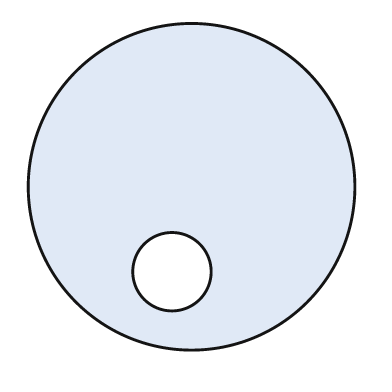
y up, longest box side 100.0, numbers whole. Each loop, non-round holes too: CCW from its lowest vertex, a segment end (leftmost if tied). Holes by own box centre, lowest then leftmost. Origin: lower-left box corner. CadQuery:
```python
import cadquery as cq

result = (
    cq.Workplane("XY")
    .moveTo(50.0, 50.0)
    .circle(50.0)
    .moveTo(44.0, 24.0)
    .circle(12.0)
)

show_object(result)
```